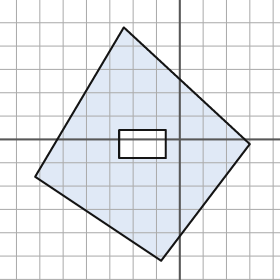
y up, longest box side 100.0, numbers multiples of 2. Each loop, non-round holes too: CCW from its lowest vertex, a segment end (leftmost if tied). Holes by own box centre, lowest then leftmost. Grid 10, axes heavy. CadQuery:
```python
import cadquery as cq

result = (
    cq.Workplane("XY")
    .moveTo(-8.0, -52.0)
    .lineTo(30.0, -2.0)
    .lineTo(-24.0, 48.0)
    .lineTo(-62.0, -16.0)
    .close()
    .moveTo(-26.0, -8.0)
    .lineTo(-6.0, -8.0)
    .lineTo(-6.0, 4.0)
    .lineTo(-26.0, 4.0)
    .close()
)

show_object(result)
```